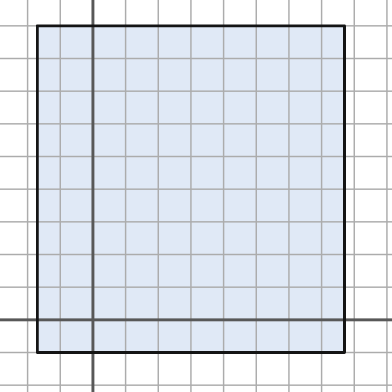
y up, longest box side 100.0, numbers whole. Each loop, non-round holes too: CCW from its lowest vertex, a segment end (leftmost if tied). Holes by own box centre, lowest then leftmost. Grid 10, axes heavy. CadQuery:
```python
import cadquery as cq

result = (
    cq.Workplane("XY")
    .moveTo(-17.0, -10.0)
    .lineTo(77.0, -10.0)
    .lineTo(77.0, 90.0)
    .lineTo(-17.0, 90.0)
    .close()
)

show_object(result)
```